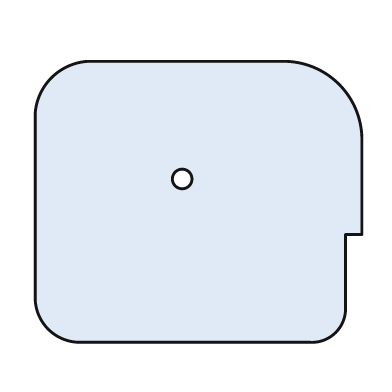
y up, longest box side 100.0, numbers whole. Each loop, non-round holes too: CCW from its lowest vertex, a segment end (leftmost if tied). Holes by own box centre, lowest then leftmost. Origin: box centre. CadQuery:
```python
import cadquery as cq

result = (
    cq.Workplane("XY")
    .moveTo(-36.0, -43.0)
    .lineTo(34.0, -43.0)
    .threePointArc((42.0, -40.0), (45.0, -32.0))
    .lineTo(45.0, -10.0)
    .lineTo(50.0, -10.0)
    .lineTo(50.0, 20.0)
    .threePointArc((43.0, 36.0), (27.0, 43.0))
    .lineTo(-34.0, 43.0)
    .threePointArc((-45.0, 38.0), (-50.0, 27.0))
    .lineTo(-50.0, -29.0)
    .threePointArc((-46.0, -39.0), (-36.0, -43.0))
    .close()
    .moveTo(-5.0, 7.0)
    .circle(3.0)
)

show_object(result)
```